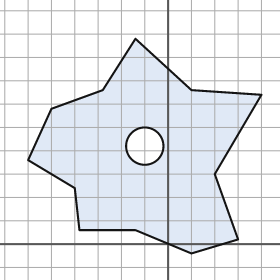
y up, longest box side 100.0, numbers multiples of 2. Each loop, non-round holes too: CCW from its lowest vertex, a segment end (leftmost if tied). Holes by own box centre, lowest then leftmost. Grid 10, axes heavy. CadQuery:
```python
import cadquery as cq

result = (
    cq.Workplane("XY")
    .moveTo(10.0, -4.0)
    .lineTo(30.0, 2.0)
    .lineTo(20.0, 30.0)
    .lineTo(40.0, 64.0)
    .lineTo(10.0, 66.0)
    .lineTo(-14.0, 88.0)
    .lineTo(-28.0, 66.0)
    .lineTo(-50.0, 58.0)
    .lineTo(-60.0, 36.0)
    .lineTo(-40.0, 24.0)
    .lineTo(-38.0, 6.0)
    .lineTo(-14.0, 6.0)
    .close()
    .moveTo(-10.0, 42.0)
    .circle(8.0)
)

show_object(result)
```